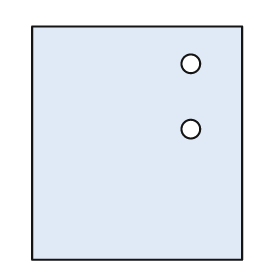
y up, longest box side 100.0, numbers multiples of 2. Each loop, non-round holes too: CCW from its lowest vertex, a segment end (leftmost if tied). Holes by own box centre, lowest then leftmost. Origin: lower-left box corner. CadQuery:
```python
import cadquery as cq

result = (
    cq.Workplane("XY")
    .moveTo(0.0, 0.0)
    .lineTo(90.0, 0.0)
    .lineTo(90.0, 100.0)
    .lineTo(0.0, 100.0)
    .close()
    .moveTo(68.0, 56.0)
    .circle(4.0)
    .moveTo(68.0, 84.0)
    .circle(4.0)
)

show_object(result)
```